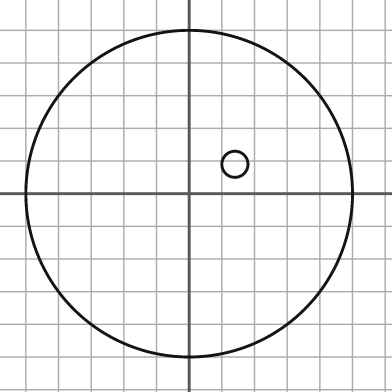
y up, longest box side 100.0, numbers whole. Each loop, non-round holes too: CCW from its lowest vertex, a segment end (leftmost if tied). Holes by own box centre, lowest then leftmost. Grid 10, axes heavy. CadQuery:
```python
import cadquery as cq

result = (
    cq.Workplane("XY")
    .moveTo(0.0, 0.0)
    .circle(50.0)
    .moveTo(14.0, 9.0)
    .circle(4.0)
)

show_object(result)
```